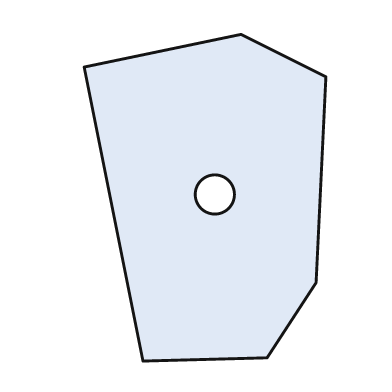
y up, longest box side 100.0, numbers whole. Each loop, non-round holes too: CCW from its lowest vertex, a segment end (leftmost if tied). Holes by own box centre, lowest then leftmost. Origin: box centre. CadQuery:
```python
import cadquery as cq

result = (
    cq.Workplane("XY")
    .moveTo(-19.0, -50.0)
    .lineTo(19.0, -49.0)
    .lineTo(34.0, -26.0)
    .lineTo(37.0, 37.0)
    .lineTo(11.0, 50.0)
    .lineTo(-37.0, 40.0)
    .close()
    .moveTo(3.0, 1.0)
    .circle(6.0)
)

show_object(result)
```